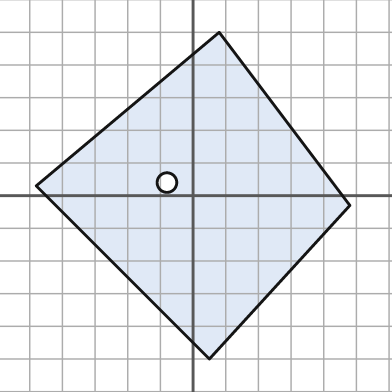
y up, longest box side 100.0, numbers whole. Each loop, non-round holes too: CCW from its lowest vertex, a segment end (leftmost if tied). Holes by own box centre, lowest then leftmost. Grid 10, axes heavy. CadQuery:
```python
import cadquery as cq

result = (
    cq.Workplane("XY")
    .moveTo(5.0, -50.0)
    .lineTo(48.0, -3.0)
    .lineTo(8.0, 50.0)
    .lineTo(-48.0, 3.0)
    .close()
    .moveTo(-8.0, 4.0)
    .circle(3.0)
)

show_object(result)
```